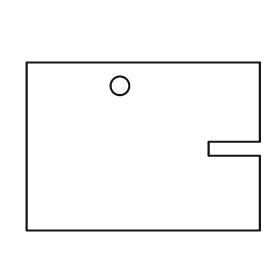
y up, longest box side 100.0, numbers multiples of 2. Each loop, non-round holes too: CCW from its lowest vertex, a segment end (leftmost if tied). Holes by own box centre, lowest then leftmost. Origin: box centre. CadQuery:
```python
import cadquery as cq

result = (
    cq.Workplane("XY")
    .moveTo(-50.0, -36.0)
    .lineTo(50.0, -36.0)
    .lineTo(50.0, -4.0)
    .lineTo(28.0, -4.0)
    .lineTo(28.0, 2.0)
    .lineTo(50.0, 2.0)
    .lineTo(50.0, 36.0)
    .lineTo(-50.0, 36.0)
    .close()
    .moveTo(-10.0, 26.0)
    .circle(4.0)
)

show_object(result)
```